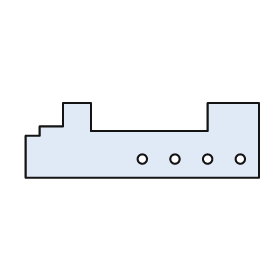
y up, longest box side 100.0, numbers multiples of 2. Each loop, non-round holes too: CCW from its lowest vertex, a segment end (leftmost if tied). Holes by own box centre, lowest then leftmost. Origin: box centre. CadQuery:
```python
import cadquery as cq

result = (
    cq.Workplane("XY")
    .moveTo(-50.0, -16.0)
    .lineTo(50.0, -16.0)
    .lineTo(50.0, 16.0)
    .lineTo(28.0, 16.0)
    .lineTo(28.0, 4.0)
    .lineTo(-22.0, 4.0)
    .lineTo(-22.0, 16.0)
    .lineTo(-34.0, 16.0)
    .lineTo(-34.0, 6.0)
    .lineTo(-44.0, 6.0)
    .lineTo(-44.0, 2.0)
    .lineTo(-50.0, 2.0)
    .close()
    .moveTo(0.0, -8.0)
    .circle(2.0)
    .moveTo(14.0, -8.0)
    .circle(2.0)
    .moveTo(28.0, -8.0)
    .circle(2.0)
    .moveTo(42.0, -8.0)
    .circle(2.0)
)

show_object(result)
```